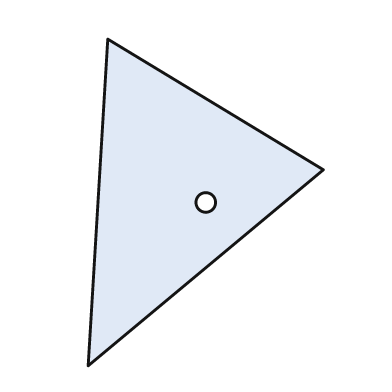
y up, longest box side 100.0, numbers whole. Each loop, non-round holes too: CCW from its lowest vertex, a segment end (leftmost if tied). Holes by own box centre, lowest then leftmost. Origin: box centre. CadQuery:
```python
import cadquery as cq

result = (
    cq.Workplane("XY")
    .moveTo(-36.0, -50.0)
    .lineTo(36.0, 10.0)
    .lineTo(-30.0, 50.0)
    .close()
    .moveTo(0.0, 0.0)
    .circle(3.0)
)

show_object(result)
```